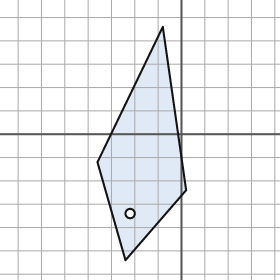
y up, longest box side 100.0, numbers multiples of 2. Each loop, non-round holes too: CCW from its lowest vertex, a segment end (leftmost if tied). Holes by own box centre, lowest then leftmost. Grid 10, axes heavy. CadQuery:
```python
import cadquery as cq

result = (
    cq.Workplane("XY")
    .moveTo(-24.0, -54.0)
    .lineTo(2.0, -24.0)
    .lineTo(-8.0, 46.0)
    .lineTo(-36.0, -12.0)
    .close()
    .moveTo(-22.0, -34.0)
    .circle(2.0)
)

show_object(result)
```